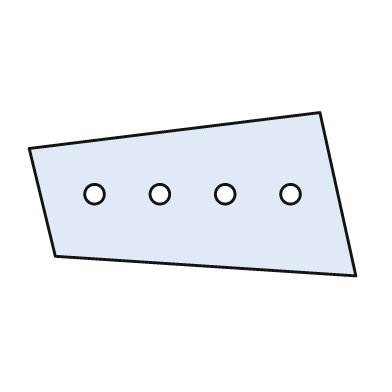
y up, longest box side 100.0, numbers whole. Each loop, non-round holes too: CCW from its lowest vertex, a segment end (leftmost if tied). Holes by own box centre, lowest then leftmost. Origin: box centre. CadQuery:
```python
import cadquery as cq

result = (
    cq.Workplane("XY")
    .moveTo(50.0, -25.0)
    .lineTo(39.0, 25.0)
    .lineTo(-50.0, 14.0)
    .lineTo(-42.0, -19.0)
    .close()
    .moveTo(-30.0, 0.0)
    .circle(3.0)
    .moveTo(-10.0, 0.0)
    .circle(3.0)
    .moveTo(10.0, 0.0)
    .circle(3.0)
    .moveTo(30.0, 0.0)
    .circle(3.0)
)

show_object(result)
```